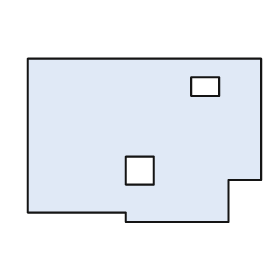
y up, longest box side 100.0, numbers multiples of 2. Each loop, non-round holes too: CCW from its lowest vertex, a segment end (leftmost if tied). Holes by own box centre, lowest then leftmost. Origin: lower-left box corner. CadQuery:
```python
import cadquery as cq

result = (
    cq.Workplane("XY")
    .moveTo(42.0, 0.0)
    .lineTo(86.0, 0.0)
    .lineTo(86.0, 18.0)
    .lineTo(100.0, 18.0)
    .lineTo(100.0, 70.0)
    .lineTo(0.0, 70.0)
    .lineTo(0.0, 4.0)
    .lineTo(42.0, 4.0)
    .close()
    .moveTo(42.0, 16.0)
    .lineTo(54.0, 16.0)
    .lineTo(54.0, 28.0)
    .lineTo(42.0, 28.0)
    .close()
    .moveTo(70.0, 54.0)
    .lineTo(82.0, 54.0)
    .lineTo(82.0, 62.0)
    .lineTo(70.0, 62.0)
    .close()
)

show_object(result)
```